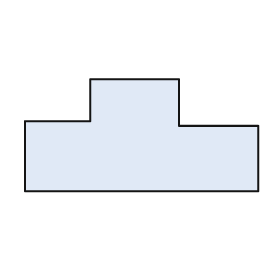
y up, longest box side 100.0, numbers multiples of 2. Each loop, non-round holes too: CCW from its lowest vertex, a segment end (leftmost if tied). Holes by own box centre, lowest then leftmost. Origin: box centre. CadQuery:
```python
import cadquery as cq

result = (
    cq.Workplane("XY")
    .moveTo(-50.0, -24.0)
    .lineTo(50.0, -24.0)
    .lineTo(50.0, 4.0)
    .lineTo(16.0, 4.0)
    .lineTo(16.0, 24.0)
    .lineTo(-22.0, 24.0)
    .lineTo(-22.0, 6.0)
    .lineTo(-50.0, 6.0)
    .close()
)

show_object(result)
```